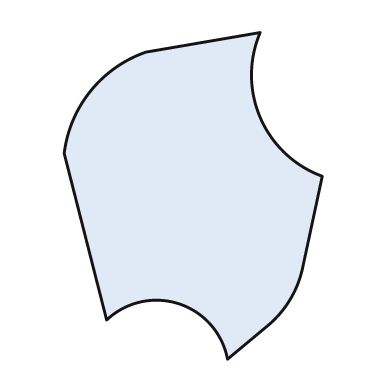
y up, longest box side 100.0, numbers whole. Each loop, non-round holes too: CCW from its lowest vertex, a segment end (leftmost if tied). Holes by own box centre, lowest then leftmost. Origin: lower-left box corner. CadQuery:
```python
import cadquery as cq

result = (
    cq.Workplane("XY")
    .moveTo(50.0, 0.0)
    .lineTo(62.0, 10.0)
    .threePointArc((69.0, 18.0), (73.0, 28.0))
    .lineTo(79.0, 56.0)
    .threePointArc((60.0, 74.0), (60.0, 100.0))
    .lineTo(25.0, 94.0)
    .threePointArc((8.0, 82.0), (0.0, 63.0))
    .lineTo(13.0, 12.0)
    .threePointArc((35.0, 17.0), (50.0, 0.0))
    .close()
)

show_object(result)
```